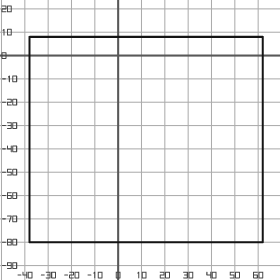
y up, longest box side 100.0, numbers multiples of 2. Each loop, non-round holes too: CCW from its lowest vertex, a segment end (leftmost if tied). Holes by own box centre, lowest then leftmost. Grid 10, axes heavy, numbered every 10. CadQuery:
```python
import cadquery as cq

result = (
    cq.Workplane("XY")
    .moveTo(-38.0, -80.0)
    .lineTo(62.0, -80.0)
    .lineTo(62.0, 8.0)
    .lineTo(-38.0, 8.0)
    .close()
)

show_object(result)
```